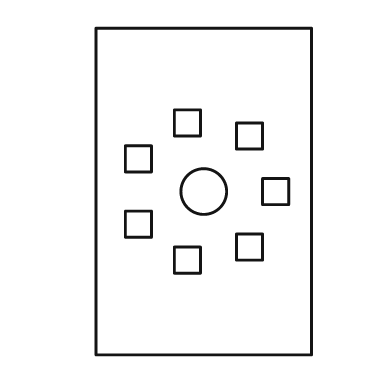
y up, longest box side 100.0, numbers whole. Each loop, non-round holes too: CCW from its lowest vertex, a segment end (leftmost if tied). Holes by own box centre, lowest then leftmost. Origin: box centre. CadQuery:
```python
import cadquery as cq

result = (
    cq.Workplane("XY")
    .moveTo(-33.0, -50.0)
    .lineTo(33.0, -50.0)
    .lineTo(33.0, 50.0)
    .lineTo(-33.0, 50.0)
    .close()
    .moveTo(-9.0, -25.0)
    .lineTo(-1.0, -25.0)
    .lineTo(-1.0, -17.0)
    .lineTo(-9.0, -17.0)
    .close()
    .moveTo(10.0, -21.0)
    .lineTo(18.0, -21.0)
    .lineTo(18.0, -13.0)
    .lineTo(10.0, -13.0)
    .close()
    .moveTo(-24.0, -14.0)
    .lineTo(-16.0, -14.0)
    .lineTo(-16.0, -6.0)
    .lineTo(-24.0, -6.0)
    .close()
    .moveTo(0.0, 0.0)
    .circle(7.0)
    .moveTo(18.0, -4.0)
    .lineTo(26.0, -4.0)
    .lineTo(26.0, 4.0)
    .lineTo(18.0, 4.0)
    .close()
    .moveTo(-24.0, 6.0)
    .lineTo(-16.0, 6.0)
    .lineTo(-16.0, 14.0)
    .lineTo(-24.0, 14.0)
    .close()
    .moveTo(10.0, 13.0)
    .lineTo(18.0, 13.0)
    .lineTo(18.0, 21.0)
    .lineTo(10.0, 21.0)
    .close()
    .moveTo(-9.0, 17.0)
    .lineTo(-1.0, 17.0)
    .lineTo(-1.0, 25.0)
    .lineTo(-9.0, 25.0)
    .close()
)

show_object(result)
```